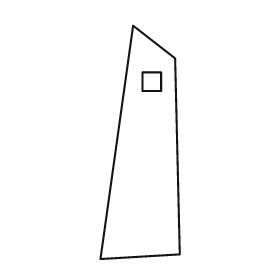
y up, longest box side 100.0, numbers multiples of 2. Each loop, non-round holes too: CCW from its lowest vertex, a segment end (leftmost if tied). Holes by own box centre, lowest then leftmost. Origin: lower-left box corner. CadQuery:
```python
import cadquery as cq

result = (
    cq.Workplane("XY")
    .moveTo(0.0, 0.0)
    .lineTo(34.0, 2.0)
    .lineTo(32.0, 86.0)
    .lineTo(14.0, 100.0)
    .close()
    .moveTo(18.0, 72.0)
    .lineTo(26.0, 72.0)
    .lineTo(26.0, 80.0)
    .lineTo(18.0, 80.0)
    .close()
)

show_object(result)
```